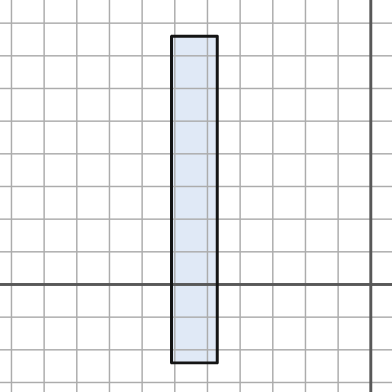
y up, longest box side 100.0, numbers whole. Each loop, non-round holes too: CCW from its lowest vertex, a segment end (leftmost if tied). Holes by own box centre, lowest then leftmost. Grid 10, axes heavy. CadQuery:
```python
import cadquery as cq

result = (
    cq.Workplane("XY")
    .moveTo(-61.0, -24.0)
    .lineTo(-47.0, -24.0)
    .lineTo(-47.0, 76.0)
    .lineTo(-61.0, 76.0)
    .close()
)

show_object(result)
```